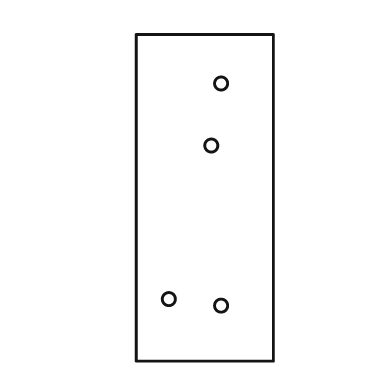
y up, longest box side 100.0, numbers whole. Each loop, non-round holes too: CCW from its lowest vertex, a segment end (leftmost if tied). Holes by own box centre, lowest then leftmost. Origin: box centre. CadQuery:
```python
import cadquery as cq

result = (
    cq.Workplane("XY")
    .moveTo(-21.0, -50.0)
    .lineTo(21.0, -50.0)
    .lineTo(21.0, 50.0)
    .lineTo(-21.0, 50.0)
    .close()
    .moveTo(5.0, -33.0)
    .circle(2.0)
    .moveTo(-11.0, -31.0)
    .circle(2.0)
    .moveTo(2.0, 16.0)
    .circle(2.0)
    .moveTo(5.0, 35.0)
    .circle(2.0)
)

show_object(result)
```